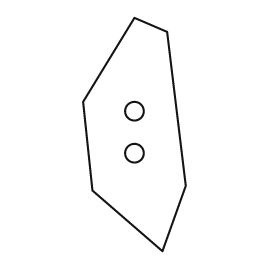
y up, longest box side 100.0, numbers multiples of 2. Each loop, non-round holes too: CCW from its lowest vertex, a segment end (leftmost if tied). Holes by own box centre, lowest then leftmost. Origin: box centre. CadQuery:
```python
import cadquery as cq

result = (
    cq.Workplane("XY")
    .moveTo(12.0, -50.0)
    .lineTo(22.0, -22.0)
    .lineTo(14.0, 44.0)
    .lineTo(0.0, 50.0)
    .lineTo(-22.0, 14.0)
    .lineTo(-18.0, -24.0)
    .close()
    .moveTo(0.0, -8.0)
    .circle(4.0)
    .moveTo(0.0, 10.0)
    .circle(4.0)
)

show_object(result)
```